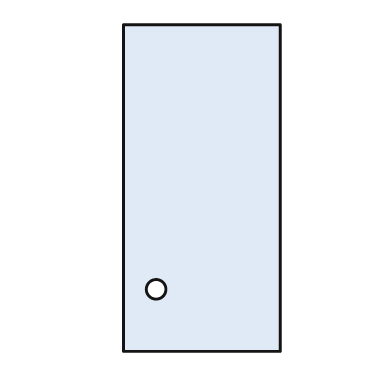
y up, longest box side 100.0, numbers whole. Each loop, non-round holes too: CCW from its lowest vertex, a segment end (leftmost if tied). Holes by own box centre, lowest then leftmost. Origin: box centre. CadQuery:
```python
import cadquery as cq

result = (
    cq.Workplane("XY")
    .moveTo(-24.0, -50.0)
    .lineTo(24.0, -50.0)
    .lineTo(24.0, 50.0)
    .lineTo(-24.0, 50.0)
    .close()
    .moveTo(-14.0, -31.0)
    .circle(3.0)
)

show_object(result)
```